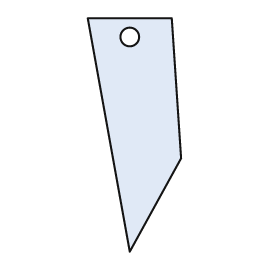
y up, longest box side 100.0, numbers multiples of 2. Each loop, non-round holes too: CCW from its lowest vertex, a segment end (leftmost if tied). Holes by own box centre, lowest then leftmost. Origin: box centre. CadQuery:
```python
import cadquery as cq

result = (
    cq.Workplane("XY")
    .moveTo(-2.0, -50.0)
    .lineTo(20.0, -10.0)
    .lineTo(16.0, 50.0)
    .lineTo(-20.0, 50.0)
    .close()
    .moveTo(-2.0, 42.0)
    .circle(4.0)
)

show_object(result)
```